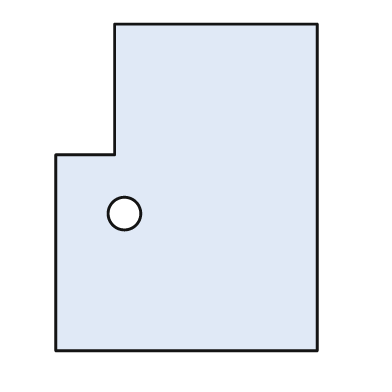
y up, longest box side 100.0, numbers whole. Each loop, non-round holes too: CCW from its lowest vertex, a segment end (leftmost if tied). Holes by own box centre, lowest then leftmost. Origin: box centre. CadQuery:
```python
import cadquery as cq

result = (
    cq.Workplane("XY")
    .moveTo(-40.0, -50.0)
    .lineTo(40.0, -50.0)
    .lineTo(40.0, 50.0)
    .lineTo(-22.0, 50.0)
    .lineTo(-22.0, 10.0)
    .lineTo(-40.0, 10.0)
    .close()
    .moveTo(-19.0, -8.0)
    .circle(5.0)
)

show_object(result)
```